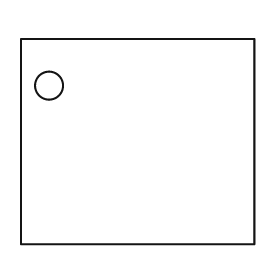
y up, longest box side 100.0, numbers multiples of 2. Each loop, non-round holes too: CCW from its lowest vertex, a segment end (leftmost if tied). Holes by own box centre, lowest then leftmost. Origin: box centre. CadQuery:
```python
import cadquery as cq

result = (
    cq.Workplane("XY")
    .moveTo(-50.0, -44.0)
    .lineTo(50.0, -44.0)
    .lineTo(50.0, 44.0)
    .lineTo(-50.0, 44.0)
    .close()
    .moveTo(-38.0, 24.0)
    .circle(6.0)
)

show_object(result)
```